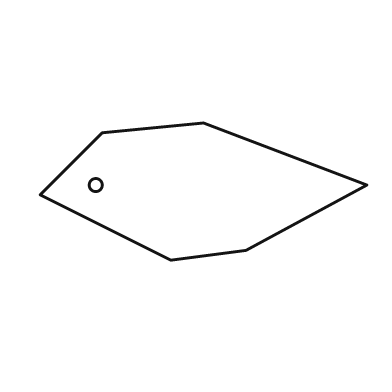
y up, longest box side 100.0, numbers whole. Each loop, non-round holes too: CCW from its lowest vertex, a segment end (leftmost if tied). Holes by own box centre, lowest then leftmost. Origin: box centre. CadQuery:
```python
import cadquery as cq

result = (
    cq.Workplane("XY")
    .moveTo(-10.0, -21.0)
    .lineTo(13.0, -18.0)
    .lineTo(50.0, 2.0)
    .lineTo(0.0, 21.0)
    .lineTo(-31.0, 18.0)
    .lineTo(-50.0, -1.0)
    .close()
    .moveTo(-33.0, 2.0)
    .circle(2.0)
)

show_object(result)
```